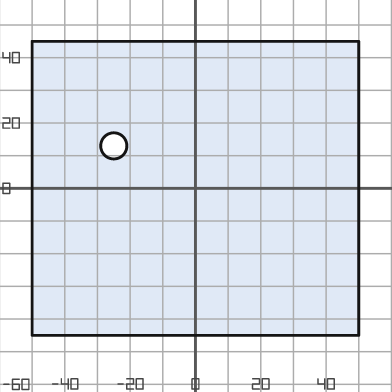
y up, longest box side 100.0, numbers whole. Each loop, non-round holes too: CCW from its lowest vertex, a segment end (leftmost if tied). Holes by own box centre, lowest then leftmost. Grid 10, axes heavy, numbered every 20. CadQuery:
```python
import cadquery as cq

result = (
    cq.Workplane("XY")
    .moveTo(-50.0, -45.0)
    .lineTo(50.0, -45.0)
    .lineTo(50.0, 45.0)
    .lineTo(-50.0, 45.0)
    .close()
    .moveTo(-25.0, 13.0)
    .circle(4.0)
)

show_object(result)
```